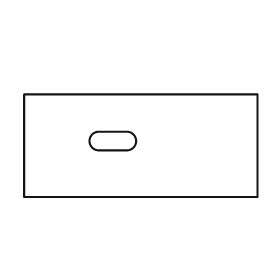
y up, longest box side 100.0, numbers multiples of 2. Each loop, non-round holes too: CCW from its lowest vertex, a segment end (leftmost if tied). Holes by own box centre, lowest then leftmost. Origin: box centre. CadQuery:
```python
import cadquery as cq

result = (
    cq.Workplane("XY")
    .moveTo(-50.0, -22.0)
    .lineTo(50.0, -22.0)
    .lineTo(50.0, 22.0)
    .lineTo(-50.0, 22.0)
    .close()
    .moveTo(-18.0, -2.0)
    .lineTo(-6.0, -2.0)
    .threePointArc((-2.0, 2.0), (-6.0, 6.0))
    .lineTo(-18.0, 6.0)
    .threePointArc((-22.0, 2.0), (-18.0, -2.0))
    .close()
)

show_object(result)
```